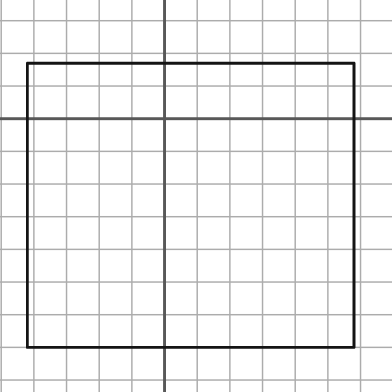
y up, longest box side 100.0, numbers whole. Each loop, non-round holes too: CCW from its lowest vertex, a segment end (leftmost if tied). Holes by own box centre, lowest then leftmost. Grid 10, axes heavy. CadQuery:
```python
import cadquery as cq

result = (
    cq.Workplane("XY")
    .moveTo(-42.0, -70.0)
    .lineTo(58.0, -70.0)
    .lineTo(58.0, 17.0)
    .lineTo(-42.0, 17.0)
    .close()
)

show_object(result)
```